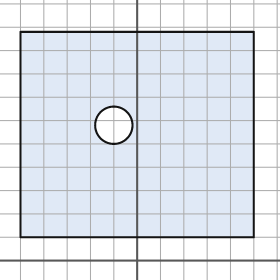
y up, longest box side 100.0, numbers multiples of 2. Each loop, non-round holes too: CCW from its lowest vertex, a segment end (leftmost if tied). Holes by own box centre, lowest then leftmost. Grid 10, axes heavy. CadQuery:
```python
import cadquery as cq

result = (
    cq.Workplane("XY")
    .moveTo(-50.0, 10.0)
    .lineTo(50.0, 10.0)
    .lineTo(50.0, 98.0)
    .lineTo(-50.0, 98.0)
    .close()
    .moveTo(-10.0, 58.0)
    .circle(8.0)
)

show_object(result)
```